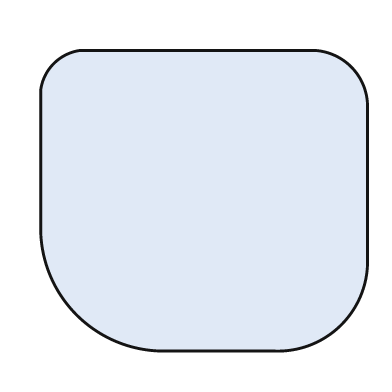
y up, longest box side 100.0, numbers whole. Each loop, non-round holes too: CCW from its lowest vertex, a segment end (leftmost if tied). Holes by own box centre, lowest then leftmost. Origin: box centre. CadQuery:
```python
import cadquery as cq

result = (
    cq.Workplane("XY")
    .moveTo(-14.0, -46.0)
    .lineTo(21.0, -46.0)
    .threePointArc((42.0, -38.0), (50.0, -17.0))
    .lineTo(50.0, 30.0)
    .threePointArc((45.0, 41.0), (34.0, 46.0))
    .lineTo(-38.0, 46.0)
    .threePointArc((-46.0, 42.0), (-50.0, 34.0))
    .lineTo(-50.0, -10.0)
    .threePointArc((-39.0, -35.0), (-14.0, -46.0))
    .close()
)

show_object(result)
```